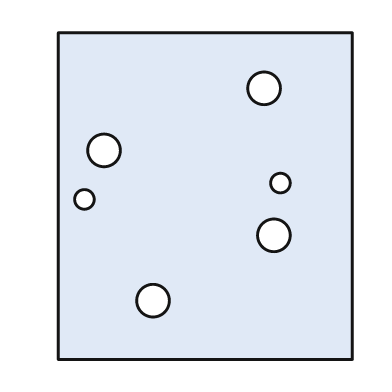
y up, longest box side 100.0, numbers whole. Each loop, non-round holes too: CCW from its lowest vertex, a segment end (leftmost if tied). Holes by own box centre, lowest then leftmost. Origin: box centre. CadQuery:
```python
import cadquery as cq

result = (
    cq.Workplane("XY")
    .moveTo(-45.0, -50.0)
    .lineTo(45.0, -50.0)
    .lineTo(45.0, 50.0)
    .lineTo(-45.0, 50.0)
    .close()
    .moveTo(-16.0, -32.0)
    .circle(5.0)
    .moveTo(21.0, -12.0)
    .circle(5.0)
    .moveTo(-37.0, -1.0)
    .circle(3.0)
    .moveTo(23.0, 4.0)
    .circle(3.0)
    .moveTo(-31.0, 14.0)
    .circle(5.0)
    .moveTo(18.0, 33.0)
    .circle(5.0)
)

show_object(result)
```